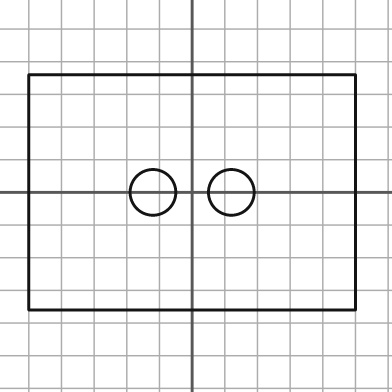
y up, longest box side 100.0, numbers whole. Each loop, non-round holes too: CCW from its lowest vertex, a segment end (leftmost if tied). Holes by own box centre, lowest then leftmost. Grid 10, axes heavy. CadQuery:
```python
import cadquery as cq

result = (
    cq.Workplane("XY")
    .moveTo(-50.0, -36.0)
    .lineTo(50.0, -36.0)
    .lineTo(50.0, 36.0)
    .lineTo(-50.0, 36.0)
    .close()
    .moveTo(-12.0, 0.0)
    .circle(7.0)
    .moveTo(12.0, 0.0)
    .circle(7.0)
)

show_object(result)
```